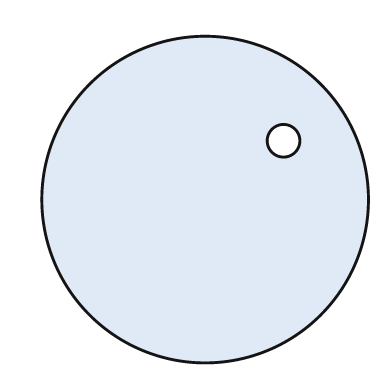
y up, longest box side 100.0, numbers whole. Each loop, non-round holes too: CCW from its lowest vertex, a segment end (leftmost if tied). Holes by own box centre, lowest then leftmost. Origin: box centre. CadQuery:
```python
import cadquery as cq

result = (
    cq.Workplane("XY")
    .moveTo(0.0, 0.0)
    .circle(50.0)
    .moveTo(24.0, 18.0)
    .circle(5.0)
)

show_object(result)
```